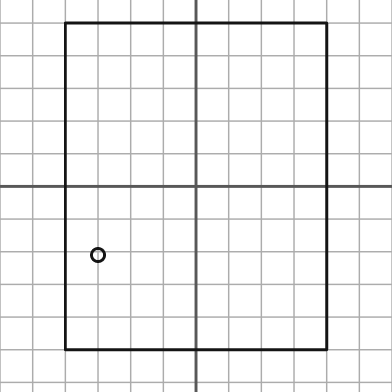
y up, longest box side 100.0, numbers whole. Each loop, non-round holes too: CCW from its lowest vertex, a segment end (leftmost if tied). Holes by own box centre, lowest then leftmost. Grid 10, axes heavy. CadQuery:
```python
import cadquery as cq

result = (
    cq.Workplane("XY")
    .moveTo(-40.0, -50.0)
    .lineTo(40.0, -50.0)
    .lineTo(40.0, 50.0)
    .lineTo(-40.0, 50.0)
    .close()
    .moveTo(-30.0, -21.0)
    .circle(2.0)
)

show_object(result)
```